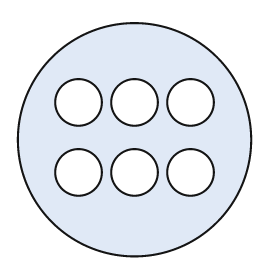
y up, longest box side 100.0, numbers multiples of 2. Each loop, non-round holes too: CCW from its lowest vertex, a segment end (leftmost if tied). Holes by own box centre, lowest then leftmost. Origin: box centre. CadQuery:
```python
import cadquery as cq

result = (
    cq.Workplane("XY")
    .moveTo(0.0, 0.0)
    .circle(50.0)
    .moveTo(-24.0, -14.0)
    .circle(10.0)
    .moveTo(0.0, -14.0)
    .circle(10.0)
    .moveTo(24.0, -14.0)
    .circle(10.0)
    .moveTo(-24.0, 16.0)
    .circle(10.0)
    .moveTo(0.0, 16.0)
    .circle(10.0)
    .moveTo(24.0, 16.0)
    .circle(10.0)
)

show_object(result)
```